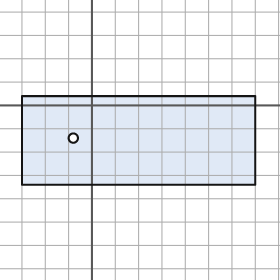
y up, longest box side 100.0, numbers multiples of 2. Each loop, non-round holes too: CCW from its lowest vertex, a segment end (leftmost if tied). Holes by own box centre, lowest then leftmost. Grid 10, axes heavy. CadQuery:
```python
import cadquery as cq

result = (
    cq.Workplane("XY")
    .moveTo(-30.0, -34.0)
    .lineTo(70.0, -34.0)
    .lineTo(70.0, 4.0)
    .lineTo(-30.0, 4.0)
    .close()
    .moveTo(-8.0, -14.0)
    .circle(2.0)
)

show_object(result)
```